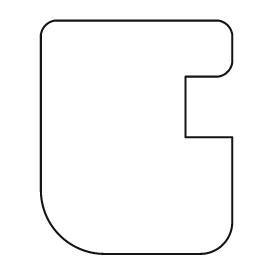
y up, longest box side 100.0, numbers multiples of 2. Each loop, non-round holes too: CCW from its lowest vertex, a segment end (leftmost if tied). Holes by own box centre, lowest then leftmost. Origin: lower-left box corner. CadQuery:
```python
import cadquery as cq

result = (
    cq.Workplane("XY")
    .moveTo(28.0, 0.0)
    .lineTo(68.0, 0.0)
    .threePointArc((78.0, 4.0), (82.0, 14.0))
    .lineTo(82.0, 50.0)
    .lineTo(62.0, 50.0)
    .lineTo(62.0, 76.0)
    .lineTo(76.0, 76.0)
    .threePointArc((80.0, 78.0), (82.0, 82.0))
    .lineTo(82.0, 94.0)
    .threePointArc((80.0, 98.0), (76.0, 100.0))
    .lineTo(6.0, 100.0)
    .threePointArc((2.0, 98.0), (0.0, 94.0))
    .lineTo(0.0, 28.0)
    .threePointArc((8.0, 8.0), (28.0, 0.0))
    .close()
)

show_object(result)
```